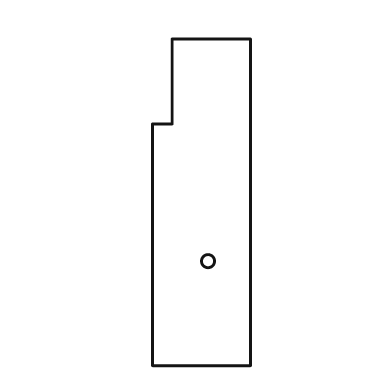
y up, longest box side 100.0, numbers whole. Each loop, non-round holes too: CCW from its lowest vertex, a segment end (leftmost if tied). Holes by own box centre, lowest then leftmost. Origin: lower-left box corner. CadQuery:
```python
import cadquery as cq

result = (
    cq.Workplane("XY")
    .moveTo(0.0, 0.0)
    .lineTo(30.0, 0.0)
    .lineTo(30.0, 100.0)
    .lineTo(6.0, 100.0)
    .lineTo(6.0, 74.0)
    .lineTo(0.0, 74.0)
    .close()
    .moveTo(17.0, 32.0)
    .circle(2.0)
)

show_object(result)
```